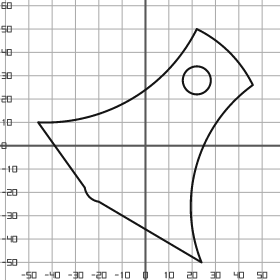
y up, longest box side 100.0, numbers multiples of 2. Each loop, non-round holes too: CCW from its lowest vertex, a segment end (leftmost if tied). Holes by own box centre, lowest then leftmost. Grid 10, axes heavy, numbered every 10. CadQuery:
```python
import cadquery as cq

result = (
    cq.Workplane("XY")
    .moveTo(24.0, -50.0)
    .threePointArc((22.0, -8.0), (46.0, 26.0))
    .threePointArc((36.0, 40.0), (22.0, 50.0))
    .threePointArc((-6.0, 20.0), (-46.0, 10.0))
    .lineTo(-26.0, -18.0)
    .threePointArc((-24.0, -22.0), (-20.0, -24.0))
    .close()
    .moveTo(22.0, 28.0)
    .circle(6.0)
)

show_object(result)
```